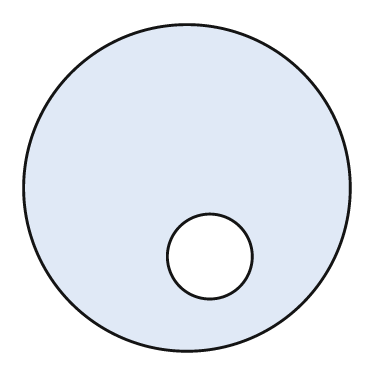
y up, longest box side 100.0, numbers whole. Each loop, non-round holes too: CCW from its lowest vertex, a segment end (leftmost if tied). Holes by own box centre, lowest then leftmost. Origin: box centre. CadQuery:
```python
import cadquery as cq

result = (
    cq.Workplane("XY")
    .moveTo(0.0, 0.0)
    .circle(50.0)
    .moveTo(7.0, -21.0)
    .circle(13.0)
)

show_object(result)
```